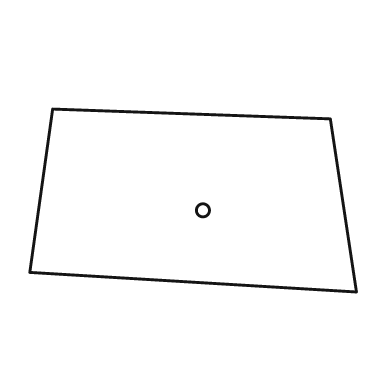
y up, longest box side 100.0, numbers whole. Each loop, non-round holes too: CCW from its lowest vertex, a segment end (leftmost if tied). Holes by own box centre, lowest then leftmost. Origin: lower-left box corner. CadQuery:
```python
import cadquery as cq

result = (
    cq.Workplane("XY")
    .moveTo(100.0, 0.0)
    .lineTo(92.0, 53.0)
    .lineTo(7.0, 56.0)
    .lineTo(0.0, 6.0)
    .close()
    .moveTo(53.0, 25.0)
    .circle(2.0)
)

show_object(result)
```